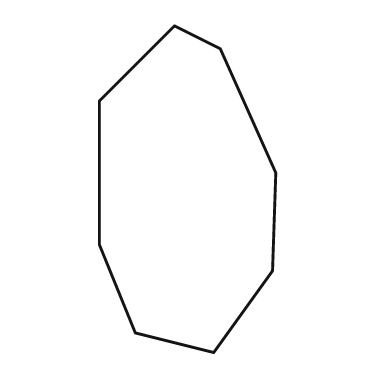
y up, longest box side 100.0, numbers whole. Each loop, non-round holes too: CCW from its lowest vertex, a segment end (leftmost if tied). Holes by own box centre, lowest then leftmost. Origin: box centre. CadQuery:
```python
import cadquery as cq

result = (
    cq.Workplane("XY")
    .moveTo(8.0, -50.0)
    .lineTo(26.0, -25.0)
    .lineTo(27.0, 5.0)
    .lineTo(10.0, 43.0)
    .lineTo(-4.0, 50.0)
    .lineTo(-27.0, 27.0)
    .lineTo(-27.0, -17.0)
    .lineTo(-16.0, -44.0)
    .close()
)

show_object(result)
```